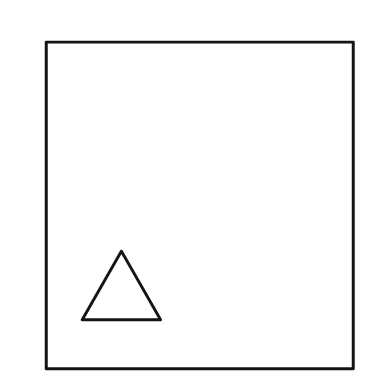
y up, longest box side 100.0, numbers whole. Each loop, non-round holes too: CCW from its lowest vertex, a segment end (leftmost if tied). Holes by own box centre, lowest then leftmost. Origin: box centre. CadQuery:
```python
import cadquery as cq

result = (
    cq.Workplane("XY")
    .moveTo(-47.0, -50.0)
    .lineTo(47.0, -50.0)
    .lineTo(47.0, 50.0)
    .lineTo(-47.0, 50.0)
    .close()
    .moveTo(-36.0, -35.0)
    .lineTo(-12.0, -35.0)
    .lineTo(-24.0, -14.0)
    .close()
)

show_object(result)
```